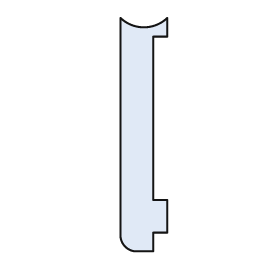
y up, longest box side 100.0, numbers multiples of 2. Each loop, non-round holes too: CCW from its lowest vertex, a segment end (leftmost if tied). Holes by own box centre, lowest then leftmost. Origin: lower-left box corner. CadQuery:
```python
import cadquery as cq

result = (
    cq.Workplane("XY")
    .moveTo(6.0, 0.0)
    .lineTo(14.0, 0.0)
    .lineTo(14.0, 8.0)
    .lineTo(20.0, 8.0)
    .lineTo(20.0, 22.0)
    .lineTo(14.0, 22.0)
    .lineTo(14.0, 92.0)
    .lineTo(20.0, 92.0)
    .lineTo(20.0, 100.0)
    .threePointArc((10.0, 96.0), (0.0, 100.0))
    .lineTo(0.0, 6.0)
    .threePointArc((2.0, 2.0), (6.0, 0.0))
    .close()
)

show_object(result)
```